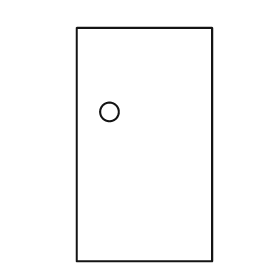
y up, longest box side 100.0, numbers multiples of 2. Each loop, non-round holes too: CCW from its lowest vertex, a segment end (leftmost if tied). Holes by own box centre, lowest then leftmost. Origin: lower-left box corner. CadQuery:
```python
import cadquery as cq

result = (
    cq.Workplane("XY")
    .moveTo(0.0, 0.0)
    .lineTo(58.0, 0.0)
    .lineTo(58.0, 100.0)
    .lineTo(0.0, 100.0)
    .close()
    .moveTo(14.0, 64.0)
    .circle(4.0)
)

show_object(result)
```